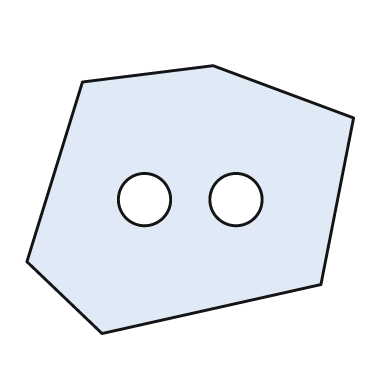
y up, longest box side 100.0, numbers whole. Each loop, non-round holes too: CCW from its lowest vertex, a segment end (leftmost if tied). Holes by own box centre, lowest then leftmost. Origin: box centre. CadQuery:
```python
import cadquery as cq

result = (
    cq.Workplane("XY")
    .moveTo(-27.0, -41.0)
    .lineTo(40.0, -26.0)
    .lineTo(50.0, 25.0)
    .lineTo(7.0, 41.0)
    .lineTo(-33.0, 36.0)
    .lineTo(-50.0, -19.0)
    .close()
    .moveTo(-14.0, 0.0)
    .circle(8.0)
    .moveTo(14.0, 0.0)
    .circle(8.0)
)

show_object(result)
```